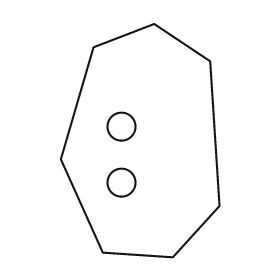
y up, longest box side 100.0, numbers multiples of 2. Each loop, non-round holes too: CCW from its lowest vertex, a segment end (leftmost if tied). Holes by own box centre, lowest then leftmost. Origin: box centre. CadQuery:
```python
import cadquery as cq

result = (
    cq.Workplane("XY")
    .moveTo(14.0, -50.0)
    .lineTo(34.0, -28.0)
    .lineTo(30.0, 34.0)
    .lineTo(6.0, 50.0)
    .lineTo(-20.0, 40.0)
    .lineTo(-34.0, -8.0)
    .lineTo(-16.0, -48.0)
    .close()
    .moveTo(-8.0, -18.0)
    .circle(6.0)
    .moveTo(-8.0, 6.0)
    .circle(6.0)
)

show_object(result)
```